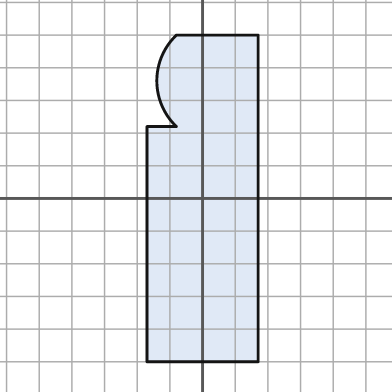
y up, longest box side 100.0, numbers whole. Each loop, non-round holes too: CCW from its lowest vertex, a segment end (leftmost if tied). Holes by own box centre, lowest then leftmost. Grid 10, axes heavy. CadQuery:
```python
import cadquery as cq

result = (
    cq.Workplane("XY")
    .moveTo(-17.0, -50.0)
    .lineTo(17.0, -50.0)
    .lineTo(17.0, 50.0)
    .lineTo(-8.0, 50.0)
    .threePointArc((-14.0, 36.0), (-8.0, 22.0))
    .lineTo(-17.0, 22.0)
    .close()
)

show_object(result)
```